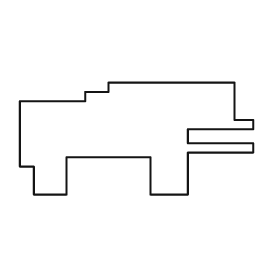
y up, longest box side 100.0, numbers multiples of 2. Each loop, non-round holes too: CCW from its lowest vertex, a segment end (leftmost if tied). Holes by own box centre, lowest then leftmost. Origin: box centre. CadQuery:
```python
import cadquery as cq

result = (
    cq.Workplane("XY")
    .moveTo(-44.0, -24.0)
    .lineTo(-30.0, -24.0)
    .lineTo(-30.0, -8.0)
    .lineTo(6.0, -8.0)
    .lineTo(6.0, -24.0)
    .lineTo(22.0, -24.0)
    .lineTo(22.0, -6.0)
    .lineTo(50.0, -6.0)
    .lineTo(50.0, -2.0)
    .lineTo(22.0, -2.0)
    .lineTo(22.0, 4.0)
    .lineTo(50.0, 4.0)
    .lineTo(50.0, 8.0)
    .lineTo(42.0, 8.0)
    .lineTo(42.0, 24.0)
    .lineTo(-12.0, 24.0)
    .lineTo(-12.0, 20.0)
    .lineTo(-22.0, 20.0)
    .lineTo(-22.0, 16.0)
    .lineTo(-50.0, 16.0)
    .lineTo(-50.0, -12.0)
    .lineTo(-44.0, -12.0)
    .close()
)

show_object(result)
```